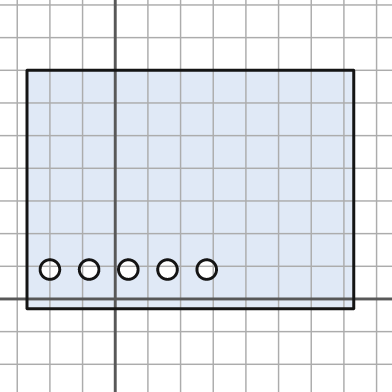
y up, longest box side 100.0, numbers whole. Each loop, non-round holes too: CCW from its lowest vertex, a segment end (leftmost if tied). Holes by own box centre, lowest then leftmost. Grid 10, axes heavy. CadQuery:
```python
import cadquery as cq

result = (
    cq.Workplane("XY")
    .moveTo(-27.0, -3.0)
    .lineTo(73.0, -3.0)
    .lineTo(73.0, 70.0)
    .lineTo(-27.0, 70.0)
    .close()
    .moveTo(-20.0, 9.0)
    .circle(3.0)
    .moveTo(-8.0, 9.0)
    .circle(3.0)
    .moveTo(4.0, 9.0)
    .circle(3.0)
    .moveTo(16.0, 9.0)
    .circle(3.0)
    .moveTo(28.0, 9.0)
    .circle(3.0)
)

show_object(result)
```